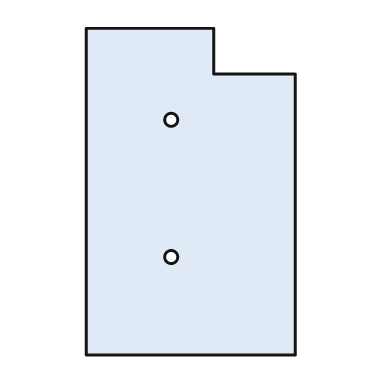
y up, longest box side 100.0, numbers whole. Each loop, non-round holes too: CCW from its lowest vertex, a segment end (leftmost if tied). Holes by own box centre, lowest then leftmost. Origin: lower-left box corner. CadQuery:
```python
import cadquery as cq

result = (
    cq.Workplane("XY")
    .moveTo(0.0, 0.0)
    .lineTo(64.0, 0.0)
    .lineTo(64.0, 86.0)
    .lineTo(39.0, 86.0)
    .lineTo(39.0, 100.0)
    .lineTo(0.0, 100.0)
    .close()
    .moveTo(26.0, 30.0)
    .circle(2.0)
    .moveTo(26.0, 72.0)
    .circle(2.0)
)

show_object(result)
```